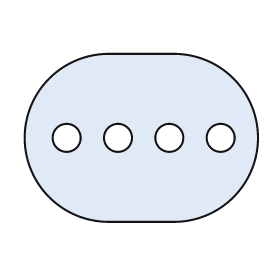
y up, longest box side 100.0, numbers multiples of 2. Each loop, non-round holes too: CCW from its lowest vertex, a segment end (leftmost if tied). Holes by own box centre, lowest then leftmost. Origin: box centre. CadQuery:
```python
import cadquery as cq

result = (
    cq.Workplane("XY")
    .moveTo(-14.0, -36.0)
    .lineTo(14.0, -36.0)
    .threePointArc((50.0, 0.0), (14.0, 36.0))
    .lineTo(-14.0, 36.0)
    .threePointArc((-50.0, 0.0), (-14.0, -36.0))
    .close()
    .moveTo(-32.0, 0.0)
    .circle(6.0)
    .moveTo(-10.0, 0.0)
    .circle(6.0)
    .moveTo(12.0, 0.0)
    .circle(6.0)
    .moveTo(34.0, 0.0)
    .circle(6.0)
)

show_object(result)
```